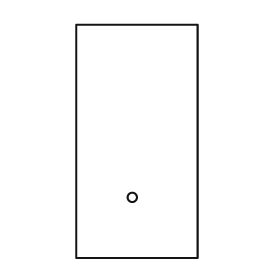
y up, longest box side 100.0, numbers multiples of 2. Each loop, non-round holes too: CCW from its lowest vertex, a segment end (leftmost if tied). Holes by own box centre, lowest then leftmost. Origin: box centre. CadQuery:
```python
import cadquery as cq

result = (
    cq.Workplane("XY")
    .moveTo(-26.0, -50.0)
    .lineTo(26.0, -50.0)
    .lineTo(26.0, 50.0)
    .lineTo(-26.0, 50.0)
    .close()
    .moveTo(-2.0, -24.0)
    .circle(2.0)
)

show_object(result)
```